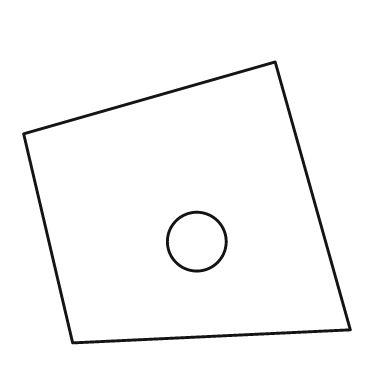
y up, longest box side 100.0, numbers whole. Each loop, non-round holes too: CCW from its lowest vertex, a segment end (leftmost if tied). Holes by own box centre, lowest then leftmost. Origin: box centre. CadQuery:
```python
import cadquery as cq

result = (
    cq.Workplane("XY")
    .moveTo(-35.0, -43.0)
    .lineTo(50.0, -39.0)
    .lineTo(27.0, 43.0)
    .lineTo(-50.0, 21.0)
    .close()
    .moveTo(3.0, -12.0)
    .circle(9.0)
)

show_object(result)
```